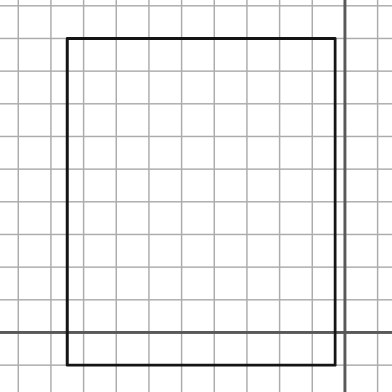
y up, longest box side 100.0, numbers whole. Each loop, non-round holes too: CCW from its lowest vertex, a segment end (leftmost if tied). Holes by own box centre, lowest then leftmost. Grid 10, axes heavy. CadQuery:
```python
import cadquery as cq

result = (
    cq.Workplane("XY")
    .moveTo(-85.0, -10.0)
    .lineTo(-3.0, -10.0)
    .lineTo(-3.0, 90.0)
    .lineTo(-85.0, 90.0)
    .close()
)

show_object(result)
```